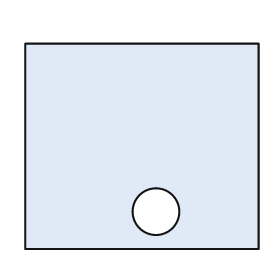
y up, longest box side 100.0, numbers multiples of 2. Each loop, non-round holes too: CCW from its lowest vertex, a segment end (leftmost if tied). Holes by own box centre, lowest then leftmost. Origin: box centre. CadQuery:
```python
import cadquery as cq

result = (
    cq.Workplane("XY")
    .moveTo(-50.0, -44.0)
    .lineTo(50.0, -44.0)
    .lineTo(50.0, 44.0)
    .lineTo(-50.0, 44.0)
    .close()
    .moveTo(6.0, -28.0)
    .circle(10.0)
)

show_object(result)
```